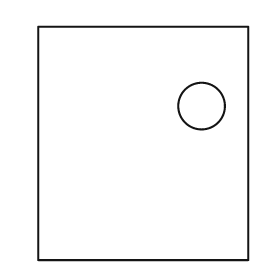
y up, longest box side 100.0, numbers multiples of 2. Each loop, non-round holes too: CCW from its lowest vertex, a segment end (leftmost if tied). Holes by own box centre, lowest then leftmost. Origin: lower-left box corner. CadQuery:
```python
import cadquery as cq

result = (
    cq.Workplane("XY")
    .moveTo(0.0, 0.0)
    .lineTo(90.0, 0.0)
    .lineTo(90.0, 100.0)
    .lineTo(0.0, 100.0)
    .close()
    .moveTo(70.0, 66.0)
    .circle(10.0)
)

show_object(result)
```